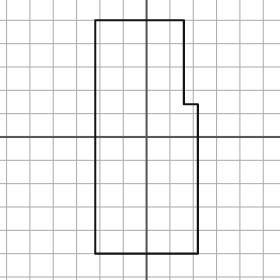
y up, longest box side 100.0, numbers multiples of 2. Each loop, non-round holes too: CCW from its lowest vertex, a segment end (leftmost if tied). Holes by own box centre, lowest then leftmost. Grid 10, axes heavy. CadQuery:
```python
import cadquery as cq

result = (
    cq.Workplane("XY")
    .moveTo(-22.0, -50.0)
    .lineTo(22.0, -50.0)
    .lineTo(22.0, 14.0)
    .lineTo(16.0, 14.0)
    .lineTo(16.0, 50.0)
    .lineTo(-22.0, 50.0)
    .close()
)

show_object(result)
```